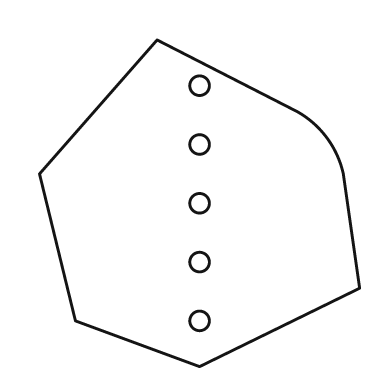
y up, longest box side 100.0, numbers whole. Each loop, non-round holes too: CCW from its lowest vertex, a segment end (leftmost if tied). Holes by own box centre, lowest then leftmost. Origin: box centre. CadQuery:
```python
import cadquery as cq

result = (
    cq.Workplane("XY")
    .moveTo(0.0, -50.0)
    .lineTo(49.0, -26.0)
    .lineTo(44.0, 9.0)
    .threePointArc((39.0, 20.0), (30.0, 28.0))
    .lineTo(-13.0, 50.0)
    .lineTo(-49.0, 9.0)
    .lineTo(-38.0, -36.0)
    .close()
    .moveTo(0.0, -36.0)
    .circle(3.0)
    .moveTo(0.0, -18.0)
    .circle(3.0)
    .moveTo(0.0, 0.0)
    .circle(3.0)
    .moveTo(0.0, 18.0)
    .circle(3.0)
    .moveTo(0.0, 36.0)
    .circle(3.0)
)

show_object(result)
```